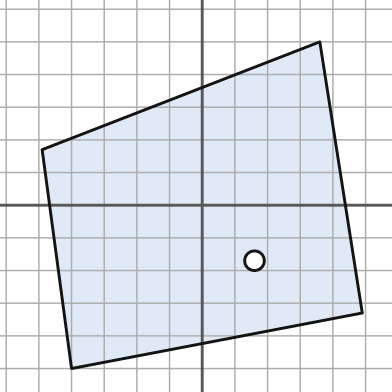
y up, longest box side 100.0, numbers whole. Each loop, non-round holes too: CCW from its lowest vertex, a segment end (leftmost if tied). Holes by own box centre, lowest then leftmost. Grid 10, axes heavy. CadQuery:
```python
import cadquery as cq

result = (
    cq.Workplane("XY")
    .moveTo(-40.0, -50.0)
    .lineTo(49.0, -33.0)
    .lineTo(36.0, 50.0)
    .lineTo(-49.0, 17.0)
    .close()
    .moveTo(16.0, -17.0)
    .circle(3.0)
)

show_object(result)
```